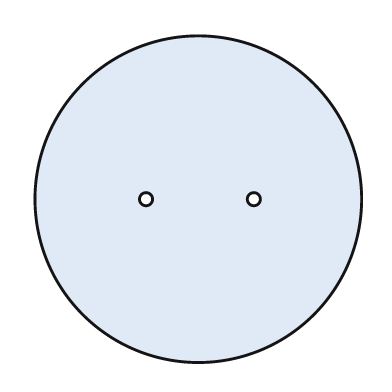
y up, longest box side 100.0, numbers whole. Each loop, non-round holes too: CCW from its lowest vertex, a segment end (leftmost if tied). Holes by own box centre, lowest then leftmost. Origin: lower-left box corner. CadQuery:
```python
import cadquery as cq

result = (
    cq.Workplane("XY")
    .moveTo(50.0, 50.0)
    .circle(50.0)
    .moveTo(34.0, 50.0)
    .circle(2.0)
    .moveTo(67.0, 50.0)
    .circle(2.0)
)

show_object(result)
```